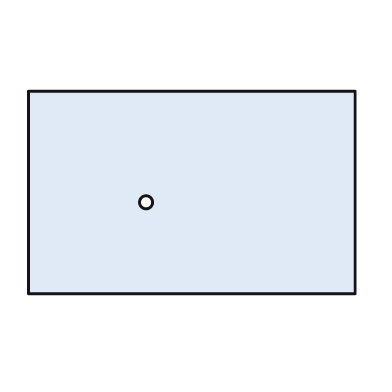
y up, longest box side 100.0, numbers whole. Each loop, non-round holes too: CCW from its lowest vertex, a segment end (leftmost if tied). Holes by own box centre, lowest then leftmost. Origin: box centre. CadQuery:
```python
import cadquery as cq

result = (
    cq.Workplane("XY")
    .moveTo(-50.0, -31.0)
    .lineTo(50.0, -31.0)
    .lineTo(50.0, 31.0)
    .lineTo(-50.0, 31.0)
    .close()
    .moveTo(-14.0, -3.0)
    .circle(2.0)
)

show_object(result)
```